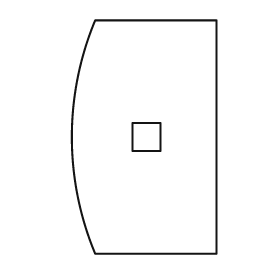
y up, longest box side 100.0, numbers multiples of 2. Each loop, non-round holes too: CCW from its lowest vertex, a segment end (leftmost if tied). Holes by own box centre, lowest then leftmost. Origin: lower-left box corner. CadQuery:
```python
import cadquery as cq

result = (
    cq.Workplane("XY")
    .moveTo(10.0, 0.0)
    .lineTo(62.0, 0.0)
    .lineTo(62.0, 100.0)
    .lineTo(10.0, 100.0)
    .threePointArc((0.0, 50.0), (10.0, 0.0))
    .close()
    .moveTo(26.0, 44.0)
    .lineTo(38.0, 44.0)
    .lineTo(38.0, 56.0)
    .lineTo(26.0, 56.0)
    .close()
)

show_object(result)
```